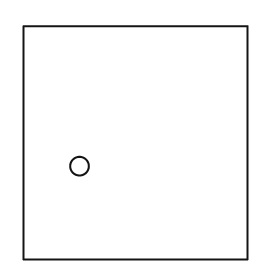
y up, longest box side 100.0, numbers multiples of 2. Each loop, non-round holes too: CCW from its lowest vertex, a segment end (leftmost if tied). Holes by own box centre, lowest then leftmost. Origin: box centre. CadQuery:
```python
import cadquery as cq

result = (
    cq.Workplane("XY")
    .moveTo(-48.0, -50.0)
    .lineTo(48.0, -50.0)
    .lineTo(48.0, 50.0)
    .lineTo(-48.0, 50.0)
    .close()
    .moveTo(-24.0, -10.0)
    .circle(4.0)
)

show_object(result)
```